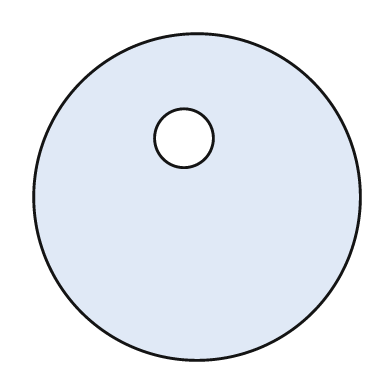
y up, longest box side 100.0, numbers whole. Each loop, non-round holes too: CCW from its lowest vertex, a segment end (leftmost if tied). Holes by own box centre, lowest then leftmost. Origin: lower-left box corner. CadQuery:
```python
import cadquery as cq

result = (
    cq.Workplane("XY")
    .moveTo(50.0, 50.0)
    .circle(50.0)
    .moveTo(46.0, 68.0)
    .circle(9.0)
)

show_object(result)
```